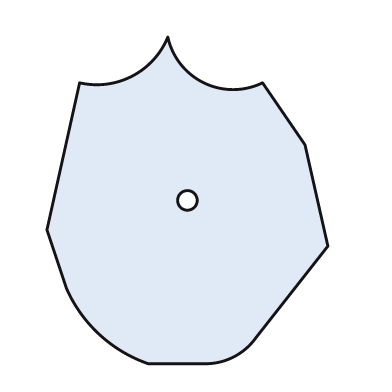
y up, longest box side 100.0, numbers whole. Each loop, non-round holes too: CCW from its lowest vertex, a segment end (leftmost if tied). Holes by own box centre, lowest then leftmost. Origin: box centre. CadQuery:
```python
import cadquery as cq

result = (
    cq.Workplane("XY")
    .moveTo(-12.0, -50.0)
    .lineTo(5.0, -50.0)
    .threePointArc((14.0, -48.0), (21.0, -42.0))
    .lineTo(43.0, -14.0)
    .lineTo(36.0, 17.0)
    .lineTo(23.0, 36.0)
    .threePointArc((5.0, 36.0), (-6.0, 50.0))
    .threePointArc((-17.0, 38.0), (-33.0, 36.0))
    .lineTo(-43.0, -9.0)
    .lineTo(-37.0, -27.0)
    .threePointArc((-27.0, -41.0), (-12.0, -50.0))
    .close()
    .moveTo(0.0, 0.0)
    .circle(3.0)
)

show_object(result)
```